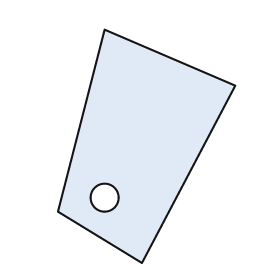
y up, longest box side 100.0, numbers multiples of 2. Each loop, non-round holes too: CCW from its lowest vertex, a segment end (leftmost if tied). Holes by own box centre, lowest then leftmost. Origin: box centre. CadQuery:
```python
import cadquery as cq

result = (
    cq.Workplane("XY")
    .moveTo(-2.0, -50.0)
    .lineTo(38.0, 26.0)
    .lineTo(-18.0, 50.0)
    .lineTo(-38.0, -28.0)
    .close()
    .moveTo(-18.0, -22.0)
    .circle(6.0)
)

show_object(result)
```